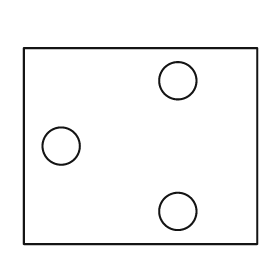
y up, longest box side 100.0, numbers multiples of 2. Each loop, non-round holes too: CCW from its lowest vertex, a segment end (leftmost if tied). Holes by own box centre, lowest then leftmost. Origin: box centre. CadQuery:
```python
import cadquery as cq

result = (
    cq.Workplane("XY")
    .moveTo(-50.0, -42.0)
    .lineTo(50.0, -42.0)
    .lineTo(50.0, 42.0)
    .lineTo(-50.0, 42.0)
    .close()
    .moveTo(16.0, -28.0)
    .circle(8.0)
    .moveTo(-34.0, 0.0)
    .circle(8.0)
    .moveTo(16.0, 28.0)
    .circle(8.0)
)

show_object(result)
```